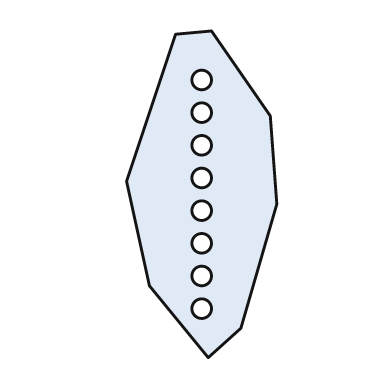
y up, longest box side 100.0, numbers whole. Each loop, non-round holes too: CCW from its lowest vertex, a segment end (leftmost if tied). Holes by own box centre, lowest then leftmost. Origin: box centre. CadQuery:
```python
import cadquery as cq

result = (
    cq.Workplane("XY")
    .moveTo(2.0, -50.0)
    .lineTo(12.0, -41.0)
    .lineTo(23.0, -3.0)
    .lineTo(21.0, 24.0)
    .lineTo(3.0, 50.0)
    .lineTo(-8.0, 49.0)
    .lineTo(-23.0, 4.0)
    .lineTo(-16.0, -28.0)
    .close()
    .moveTo(0.0, -35.0)
    .circle(3.0)
    .moveTo(0.0, -25.0)
    .circle(3.0)
    .moveTo(0.0, -15.0)
    .circle(3.0)
    .moveTo(0.0, -5.0)
    .circle(3.0)
    .moveTo(0.0, 5.0)
    .circle(3.0)
    .moveTo(0.0, 15.0)
    .circle(3.0)
    .moveTo(0.0, 25.0)
    .circle(3.0)
    .moveTo(0.0, 35.0)
    .circle(3.0)
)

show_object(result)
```